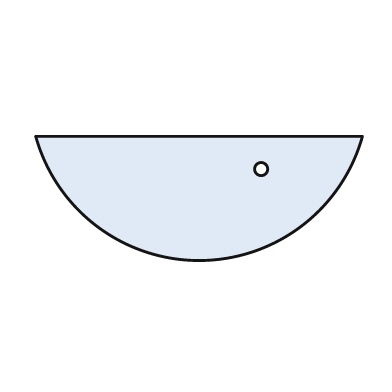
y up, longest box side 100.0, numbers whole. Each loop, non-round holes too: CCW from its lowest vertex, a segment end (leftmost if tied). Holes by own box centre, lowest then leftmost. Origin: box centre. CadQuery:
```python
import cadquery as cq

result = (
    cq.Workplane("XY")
    .moveTo(-50.0, 19.0)
    .threePointArc((0.0, -19.0), (50.0, 19.0))
    .close()
    .moveTo(19.0, 9.0)
    .circle(2.0)
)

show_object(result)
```